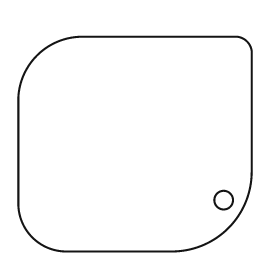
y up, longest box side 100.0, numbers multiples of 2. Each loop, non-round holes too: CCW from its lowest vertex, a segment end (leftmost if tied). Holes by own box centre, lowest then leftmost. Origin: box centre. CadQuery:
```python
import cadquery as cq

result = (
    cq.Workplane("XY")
    .moveTo(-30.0, -46.0)
    .lineTo(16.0, -46.0)
    .threePointArc((40.0, -36.0), (50.0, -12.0))
    .lineTo(50.0, 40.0)
    .threePointArc((48.0, 44.0), (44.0, 46.0))
    .lineTo(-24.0, 46.0)
    .threePointArc((-42.0, 38.0), (-50.0, 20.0))
    .lineTo(-50.0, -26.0)
    .threePointArc((-44.0, -40.0), (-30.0, -46.0))
    .close()
    .moveTo(38.0, -24.0)
    .circle(4.0)
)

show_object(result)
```